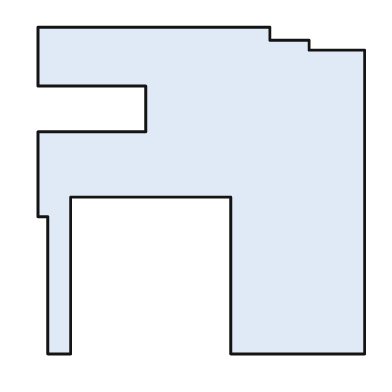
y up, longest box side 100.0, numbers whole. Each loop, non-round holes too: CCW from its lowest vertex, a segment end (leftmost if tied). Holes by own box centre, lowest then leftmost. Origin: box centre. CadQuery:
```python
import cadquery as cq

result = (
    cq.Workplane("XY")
    .moveTo(-47.0, -50.0)
    .lineTo(-40.0, -50.0)
    .lineTo(-40.0, -2.0)
    .lineTo(9.0, -2.0)
    .lineTo(9.0, -50.0)
    .lineTo(50.0, -50.0)
    .lineTo(50.0, 43.0)
    .lineTo(33.0, 43.0)
    .lineTo(33.0, 46.0)
    .lineTo(21.0, 46.0)
    .lineTo(21.0, 50.0)
    .lineTo(-50.0, 50.0)
    .lineTo(-50.0, 32.0)
    .lineTo(-17.0, 32.0)
    .lineTo(-17.0, 18.0)
    .lineTo(-50.0, 18.0)
    .lineTo(-50.0, -8.0)
    .lineTo(-47.0, -8.0)
    .close()
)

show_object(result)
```